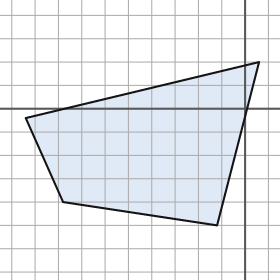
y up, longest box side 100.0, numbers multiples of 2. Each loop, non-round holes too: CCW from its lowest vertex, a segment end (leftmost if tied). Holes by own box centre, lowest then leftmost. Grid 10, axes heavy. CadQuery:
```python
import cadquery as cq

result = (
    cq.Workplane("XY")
    .moveTo(-12.0, -50.0)
    .lineTo(6.0, 20.0)
    .lineTo(-94.0, -4.0)
    .lineTo(-78.0, -40.0)
    .close()
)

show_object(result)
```